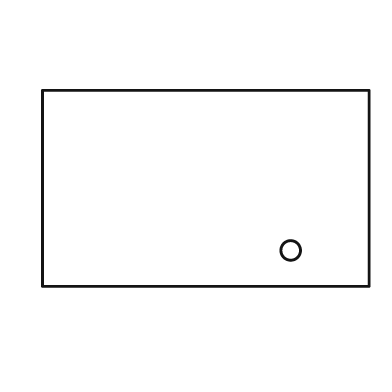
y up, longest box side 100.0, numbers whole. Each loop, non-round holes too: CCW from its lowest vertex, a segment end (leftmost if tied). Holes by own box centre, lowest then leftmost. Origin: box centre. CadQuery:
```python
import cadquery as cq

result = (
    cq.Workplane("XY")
    .moveTo(-50.0, -30.0)
    .lineTo(50.0, -30.0)
    .lineTo(50.0, 30.0)
    .lineTo(-50.0, 30.0)
    .close()
    .moveTo(26.0, -19.0)
    .circle(3.0)
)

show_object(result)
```